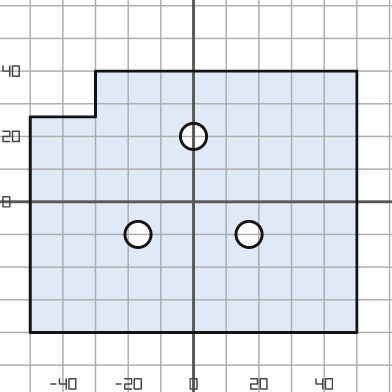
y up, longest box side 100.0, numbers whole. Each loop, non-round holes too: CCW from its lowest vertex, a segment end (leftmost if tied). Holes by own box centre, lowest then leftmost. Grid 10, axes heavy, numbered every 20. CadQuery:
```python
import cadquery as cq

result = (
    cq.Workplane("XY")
    .moveTo(-50.0, -40.0)
    .lineTo(50.0, -40.0)
    .lineTo(50.0, 40.0)
    .lineTo(-30.0, 40.0)
    .lineTo(-30.0, 26.0)
    .lineTo(-50.0, 26.0)
    .close()
    .moveTo(-17.0, -10.0)
    .circle(4.0)
    .moveTo(17.0, -10.0)
    .circle(4.0)
    .moveTo(0.0, 20.0)
    .circle(4.0)
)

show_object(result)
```